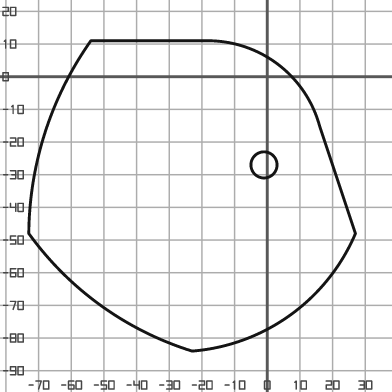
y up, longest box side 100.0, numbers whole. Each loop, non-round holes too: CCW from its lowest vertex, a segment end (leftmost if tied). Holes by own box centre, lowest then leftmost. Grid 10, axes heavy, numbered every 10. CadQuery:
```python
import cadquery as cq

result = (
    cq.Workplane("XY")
    .moveTo(-23.0, -84.0)
    .threePointArc((7.0, -73.0), (27.0, -48.0))
    .lineTo(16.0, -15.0)
    .threePointArc((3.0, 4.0), (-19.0, 11.0))
    .lineTo(-54.0, 11.0)
    .threePointArc((-68.0, -17.0), (-73.0, -48.0))
    .threePointArc((-51.0, -70.0), (-23.0, -84.0))
    .close()
    .moveTo(-1.0, -27.0)
    .circle(4.0)
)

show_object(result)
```